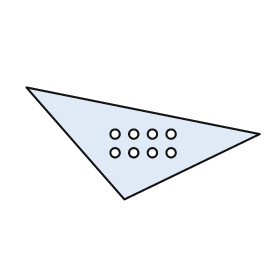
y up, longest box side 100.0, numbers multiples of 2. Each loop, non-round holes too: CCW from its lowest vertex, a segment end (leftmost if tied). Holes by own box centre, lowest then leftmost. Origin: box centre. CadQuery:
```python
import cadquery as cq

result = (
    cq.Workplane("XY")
    .moveTo(-8.0, -24.0)
    .lineTo(50.0, 4.0)
    .lineTo(-50.0, 24.0)
    .close()
    .moveTo(-12.0, -4.0)
    .circle(2.0)
    .moveTo(-4.0, -4.0)
    .circle(2.0)
    .moveTo(4.0, -4.0)
    .circle(2.0)
    .moveTo(12.0, -4.0)
    .circle(2.0)
    .moveTo(-12.0, 4.0)
    .circle(2.0)
    .moveTo(-4.0, 4.0)
    .circle(2.0)
    .moveTo(4.0, 4.0)
    .circle(2.0)
    .moveTo(12.0, 4.0)
    .circle(2.0)
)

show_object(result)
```